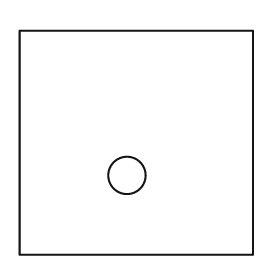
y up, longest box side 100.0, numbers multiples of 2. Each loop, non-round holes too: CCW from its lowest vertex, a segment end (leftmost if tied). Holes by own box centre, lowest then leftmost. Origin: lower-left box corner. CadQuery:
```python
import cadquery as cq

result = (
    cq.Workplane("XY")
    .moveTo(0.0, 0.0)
    .lineTo(100.0, 0.0)
    .lineTo(100.0, 96.0)
    .lineTo(0.0, 96.0)
    .close()
    .moveTo(46.0, 34.0)
    .circle(8.0)
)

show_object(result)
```